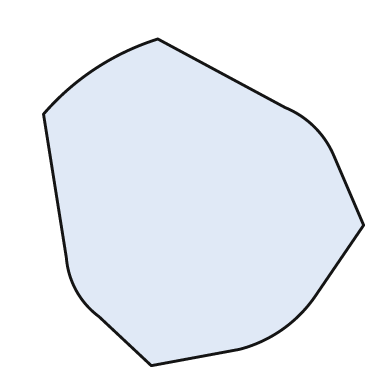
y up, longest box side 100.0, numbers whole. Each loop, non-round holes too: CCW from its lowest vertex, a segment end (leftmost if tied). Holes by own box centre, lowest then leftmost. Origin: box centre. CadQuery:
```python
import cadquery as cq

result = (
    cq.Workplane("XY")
    .moveTo(-16.0, -50.0)
    .lineTo(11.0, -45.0)
    .threePointArc((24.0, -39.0), (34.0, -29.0))
    .lineTo(49.0, -7.0)
    .lineTo(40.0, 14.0)
    .threePointArc((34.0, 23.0), (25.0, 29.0))
    .lineTo(-14.0, 50.0)
    .threePointArc((-33.0, 41.0), (-49.0, 27.0))
    .lineTo(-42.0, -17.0)
    .threePointArc((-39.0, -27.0), (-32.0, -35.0))
    .close()
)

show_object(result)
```